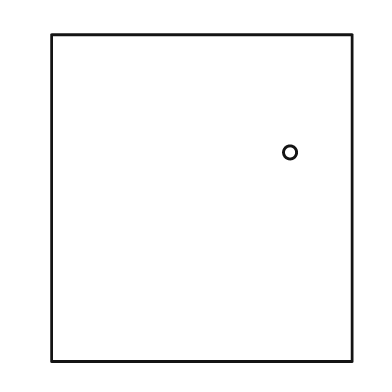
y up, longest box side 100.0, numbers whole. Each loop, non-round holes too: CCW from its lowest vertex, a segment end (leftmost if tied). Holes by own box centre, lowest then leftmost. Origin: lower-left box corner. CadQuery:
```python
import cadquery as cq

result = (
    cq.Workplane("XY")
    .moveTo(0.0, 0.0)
    .lineTo(92.0, 0.0)
    .lineTo(92.0, 100.0)
    .lineTo(0.0, 100.0)
    .close()
    .moveTo(73.0, 64.0)
    .circle(2.0)
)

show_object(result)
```